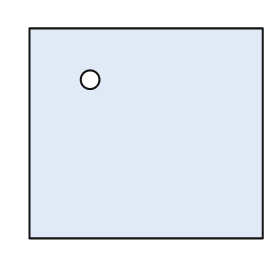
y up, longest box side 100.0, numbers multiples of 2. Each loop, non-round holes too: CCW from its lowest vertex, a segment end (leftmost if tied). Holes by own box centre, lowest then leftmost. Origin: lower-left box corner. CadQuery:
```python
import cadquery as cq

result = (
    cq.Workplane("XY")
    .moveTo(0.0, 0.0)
    .lineTo(100.0, 0.0)
    .lineTo(100.0, 90.0)
    .lineTo(0.0, 90.0)
    .close()
    .moveTo(26.0, 68.0)
    .circle(4.0)
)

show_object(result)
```